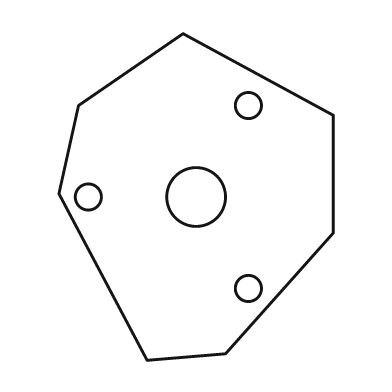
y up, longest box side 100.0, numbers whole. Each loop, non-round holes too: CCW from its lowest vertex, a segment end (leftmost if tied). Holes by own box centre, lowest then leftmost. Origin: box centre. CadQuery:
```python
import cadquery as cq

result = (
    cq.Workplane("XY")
    .moveTo(-15.0, -50.0)
    .lineTo(9.0, -48.0)
    .lineTo(42.0, -11.0)
    .lineTo(42.0, 25.0)
    .lineTo(-4.0, 50.0)
    .lineTo(-36.0, 28.0)
    .lineTo(-42.0, 1.0)
    .close()
    .moveTo(16.0, -28.0)
    .circle(4.0)
    .moveTo(-33.0, 0.0)
    .circle(4.0)
    .moveTo(0.0, 0.0)
    .circle(9.0)
    .moveTo(16.0, 28.0)
    .circle(4.0)
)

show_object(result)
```